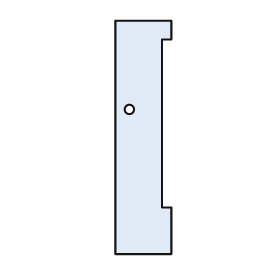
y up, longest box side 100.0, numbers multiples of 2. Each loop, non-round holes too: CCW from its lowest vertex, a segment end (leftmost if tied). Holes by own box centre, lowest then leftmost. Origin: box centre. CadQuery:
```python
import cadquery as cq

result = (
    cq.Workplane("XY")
    .moveTo(-12.0, -50.0)
    .lineTo(12.0, -50.0)
    .lineTo(12.0, -30.0)
    .lineTo(8.0, -30.0)
    .lineTo(8.0, 42.0)
    .lineTo(12.0, 42.0)
    .lineTo(12.0, 50.0)
    .lineTo(-12.0, 50.0)
    .close()
    .moveTo(-6.0, 12.0)
    .circle(2.0)
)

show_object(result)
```